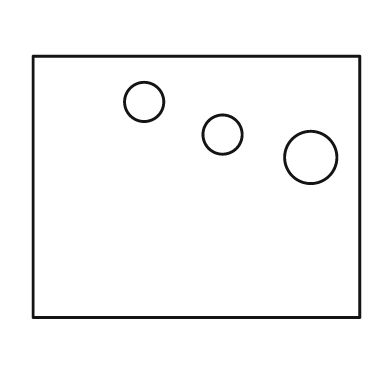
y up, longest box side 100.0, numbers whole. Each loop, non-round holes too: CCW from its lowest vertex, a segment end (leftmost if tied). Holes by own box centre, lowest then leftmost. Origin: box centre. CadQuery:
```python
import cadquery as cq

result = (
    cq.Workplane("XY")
    .moveTo(-50.0, -40.0)
    .lineTo(50.0, -40.0)
    .lineTo(50.0, 40.0)
    .lineTo(-50.0, 40.0)
    .close()
    .moveTo(35.0, 9.0)
    .circle(8.0)
    .moveTo(8.0, 16.0)
    .circle(6.0)
    .moveTo(-16.0, 26.0)
    .circle(6.0)
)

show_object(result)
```